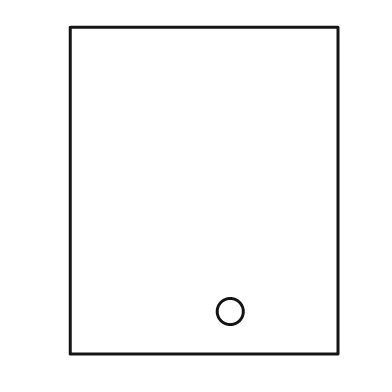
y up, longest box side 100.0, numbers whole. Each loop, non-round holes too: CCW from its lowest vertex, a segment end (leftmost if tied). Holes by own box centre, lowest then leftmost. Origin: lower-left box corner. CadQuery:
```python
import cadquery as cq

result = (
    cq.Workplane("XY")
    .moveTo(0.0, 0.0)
    .lineTo(82.0, 0.0)
    .lineTo(82.0, 100.0)
    .lineTo(0.0, 100.0)
    .close()
    .moveTo(49.0, 13.0)
    .circle(4.0)
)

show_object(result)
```